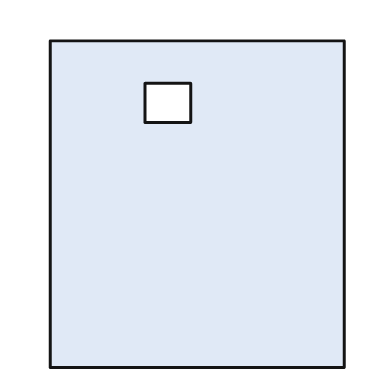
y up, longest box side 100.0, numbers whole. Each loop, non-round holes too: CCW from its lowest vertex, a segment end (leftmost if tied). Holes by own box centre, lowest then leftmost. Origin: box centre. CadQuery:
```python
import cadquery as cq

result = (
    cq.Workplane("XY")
    .moveTo(-45.0, -50.0)
    .lineTo(45.0, -50.0)
    .lineTo(45.0, 50.0)
    .lineTo(-45.0, 50.0)
    .close()
    .moveTo(-16.0, 25.0)
    .lineTo(-2.0, 25.0)
    .lineTo(-2.0, 37.0)
    .lineTo(-16.0, 37.0)
    .close()
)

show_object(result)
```